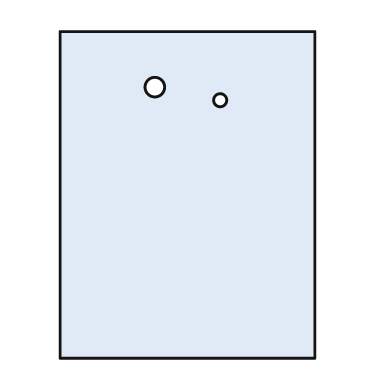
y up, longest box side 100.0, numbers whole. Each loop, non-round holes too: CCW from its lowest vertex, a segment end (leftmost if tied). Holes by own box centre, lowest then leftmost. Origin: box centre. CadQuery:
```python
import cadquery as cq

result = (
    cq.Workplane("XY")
    .moveTo(-39.0, -50.0)
    .lineTo(39.0, -50.0)
    .lineTo(39.0, 50.0)
    .lineTo(-39.0, 50.0)
    .close()
    .moveTo(10.0, 29.0)
    .circle(2.0)
    .moveTo(-10.0, 33.0)
    .circle(3.0)
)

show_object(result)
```